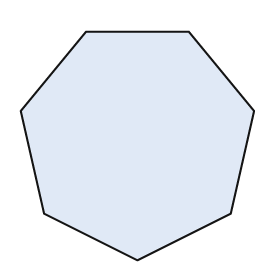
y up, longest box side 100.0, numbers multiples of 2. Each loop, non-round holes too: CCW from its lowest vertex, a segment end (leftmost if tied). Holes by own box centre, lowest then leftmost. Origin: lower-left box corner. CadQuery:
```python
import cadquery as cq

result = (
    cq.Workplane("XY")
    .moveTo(50.0, 0.0)
    .lineTo(90.0, 20.0)
    .lineTo(100.0, 64.0)
    .lineTo(72.0, 98.0)
    .lineTo(28.0, 98.0)
    .lineTo(0.0, 64.0)
    .lineTo(10.0, 20.0)
    .close()
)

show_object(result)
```